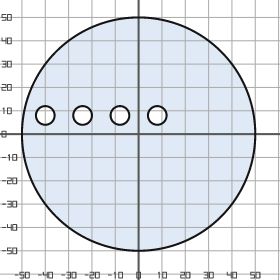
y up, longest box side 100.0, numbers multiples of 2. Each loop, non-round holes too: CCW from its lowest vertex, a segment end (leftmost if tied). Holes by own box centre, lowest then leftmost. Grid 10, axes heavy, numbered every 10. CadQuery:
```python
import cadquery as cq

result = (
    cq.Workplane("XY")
    .moveTo(0.0, 0.0)
    .circle(50.0)
    .moveTo(-40.0, 8.0)
    .circle(4.0)
    .moveTo(-24.0, 8.0)
    .circle(4.0)
    .moveTo(-8.0, 8.0)
    .circle(4.0)
    .moveTo(8.0, 8.0)
    .circle(4.0)
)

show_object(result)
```